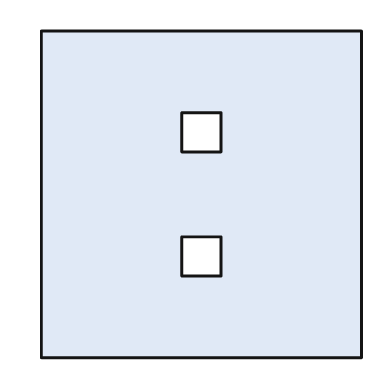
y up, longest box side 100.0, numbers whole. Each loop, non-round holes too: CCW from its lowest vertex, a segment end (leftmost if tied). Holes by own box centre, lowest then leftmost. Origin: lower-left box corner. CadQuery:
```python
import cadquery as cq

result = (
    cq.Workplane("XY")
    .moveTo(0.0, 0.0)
    .lineTo(98.0, 0.0)
    .lineTo(98.0, 100.0)
    .lineTo(0.0, 100.0)
    .close()
    .moveTo(43.0, 25.0)
    .lineTo(55.0, 25.0)
    .lineTo(55.0, 37.0)
    .lineTo(43.0, 37.0)
    .close()
    .moveTo(43.0, 63.0)
    .lineTo(55.0, 63.0)
    .lineTo(55.0, 75.0)
    .lineTo(43.0, 75.0)
    .close()
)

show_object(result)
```